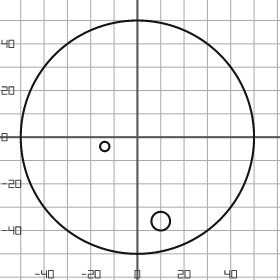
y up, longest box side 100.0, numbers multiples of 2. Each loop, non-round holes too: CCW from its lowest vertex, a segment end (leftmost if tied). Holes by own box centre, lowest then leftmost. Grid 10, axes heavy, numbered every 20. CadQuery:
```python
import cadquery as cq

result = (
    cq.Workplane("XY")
    .moveTo(0.0, 0.0)
    .circle(50.0)
    .moveTo(10.0, -36.0)
    .circle(4.0)
    .moveTo(-14.0, -4.0)
    .circle(2.0)
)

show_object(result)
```